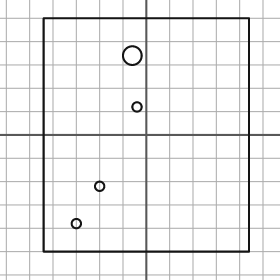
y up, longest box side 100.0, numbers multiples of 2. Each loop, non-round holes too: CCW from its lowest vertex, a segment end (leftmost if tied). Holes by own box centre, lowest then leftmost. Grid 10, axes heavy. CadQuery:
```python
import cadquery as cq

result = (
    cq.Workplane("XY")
    .moveTo(-44.0, -50.0)
    .lineTo(44.0, -50.0)
    .lineTo(44.0, 50.0)
    .lineTo(-44.0, 50.0)
    .close()
    .moveTo(-30.0, -38.0)
    .circle(2.0)
    .moveTo(-20.0, -22.0)
    .circle(2.0)
    .moveTo(-4.0, 12.0)
    .circle(2.0)
    .moveTo(-6.0, 34.0)
    .circle(4.0)
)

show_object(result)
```